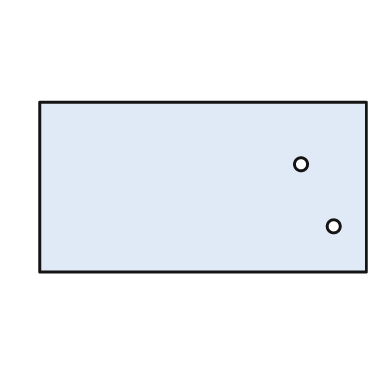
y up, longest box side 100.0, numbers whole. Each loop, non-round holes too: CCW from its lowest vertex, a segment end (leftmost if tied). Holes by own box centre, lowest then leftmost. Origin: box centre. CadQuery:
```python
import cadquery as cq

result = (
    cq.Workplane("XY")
    .moveTo(-50.0, -26.0)
    .lineTo(50.0, -26.0)
    .lineTo(50.0, 26.0)
    .lineTo(-50.0, 26.0)
    .close()
    .moveTo(40.0, -12.0)
    .circle(2.0)
    .moveTo(30.0, 7.0)
    .circle(2.0)
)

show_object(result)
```